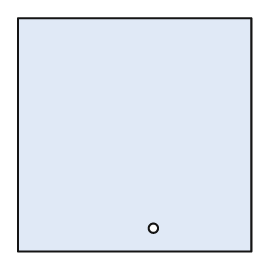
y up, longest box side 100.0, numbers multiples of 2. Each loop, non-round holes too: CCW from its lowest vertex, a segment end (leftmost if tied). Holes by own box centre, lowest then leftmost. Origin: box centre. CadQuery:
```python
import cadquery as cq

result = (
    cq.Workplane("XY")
    .moveTo(-50.0, -50.0)
    .lineTo(50.0, -50.0)
    .lineTo(50.0, 50.0)
    .lineTo(-50.0, 50.0)
    .close()
    .moveTo(8.0, -40.0)
    .circle(2.0)
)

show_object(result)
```